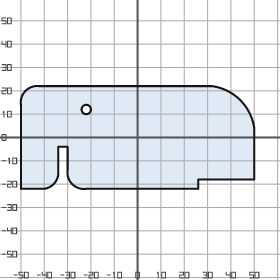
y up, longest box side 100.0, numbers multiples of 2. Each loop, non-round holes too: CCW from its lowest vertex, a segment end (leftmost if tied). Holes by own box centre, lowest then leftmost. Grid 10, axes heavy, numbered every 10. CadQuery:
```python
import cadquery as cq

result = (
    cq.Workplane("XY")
    .moveTo(-50.0, -22.0)
    .lineTo(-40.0, -22.0)
    .threePointArc((-36.0, -20.0), (-34.0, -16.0))
    .lineTo(-34.0, -4.0)
    .lineTo(-30.0, -4.0)
    .lineTo(-30.0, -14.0)
    .threePointArc((-28.0, -20.0), (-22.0, -22.0))
    .lineTo(26.0, -22.0)
    .lineTo(26.0, -18.0)
    .lineTo(50.0, -18.0)
    .lineTo(50.0, 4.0)
    .threePointArc((44.0, 16.0), (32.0, 22.0))
    .lineTo(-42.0, 22.0)
    .threePointArc((-48.0, 20.0), (-50.0, 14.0))
    .close()
    .moveTo(-22.0, 12.0)
    .circle(2.0)
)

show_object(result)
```